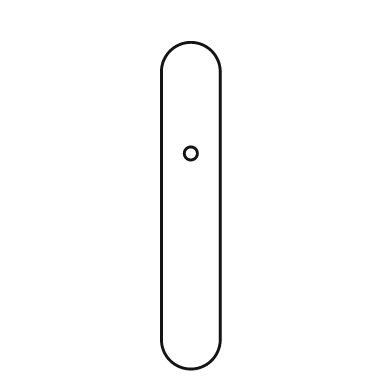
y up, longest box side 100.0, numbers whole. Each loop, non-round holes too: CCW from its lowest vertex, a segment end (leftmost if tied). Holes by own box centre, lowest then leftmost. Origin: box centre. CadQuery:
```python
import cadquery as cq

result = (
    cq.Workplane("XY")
    .moveTo(-9.0, -41.0)
    .threePointArc((0.0, -50.0), (9.0, -41.0))
    .lineTo(9.0, 41.0)
    .threePointArc((0.0, 50.0), (-9.0, 41.0))
    .close()
    .moveTo(0.0, 16.0)
    .circle(2.0)
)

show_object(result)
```